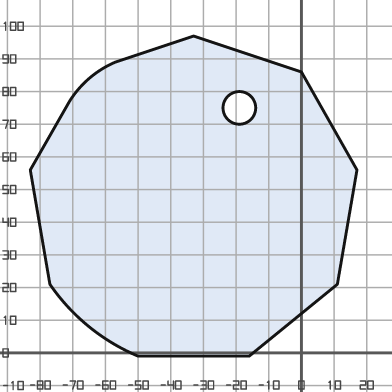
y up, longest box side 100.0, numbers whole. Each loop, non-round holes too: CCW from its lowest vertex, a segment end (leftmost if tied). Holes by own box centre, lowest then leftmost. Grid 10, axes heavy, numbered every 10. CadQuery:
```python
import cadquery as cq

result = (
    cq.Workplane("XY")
    .moveTo(-50.0, -1.0)
    .lineTo(-16.0, -1.0)
    .lineTo(11.0, 21.0)
    .lineTo(17.0, 56.0)
    .lineTo(0.0, 86.0)
    .lineTo(-33.0, 97.0)
    .lineTo(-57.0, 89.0)
    .threePointArc((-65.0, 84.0), (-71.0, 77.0))
    .lineTo(-83.0, 56.0)
    .lineTo(-77.0, 21.0)
    .threePointArc((-65.0, 8.0), (-50.0, -1.0))
    .close()
    .moveTo(-19.0, 75.0)
    .circle(5.0)
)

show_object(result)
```